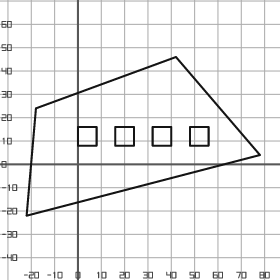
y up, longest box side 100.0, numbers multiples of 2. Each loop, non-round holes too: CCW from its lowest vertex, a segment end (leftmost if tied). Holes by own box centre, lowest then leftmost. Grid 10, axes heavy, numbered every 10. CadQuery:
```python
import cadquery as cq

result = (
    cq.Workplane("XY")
    .moveTo(-22.0, -22.0)
    .lineTo(78.0, 4.0)
    .lineTo(42.0, 46.0)
    .lineTo(-18.0, 24.0)
    .close()
    .moveTo(0.0, 8.0)
    .lineTo(8.0, 8.0)
    .lineTo(8.0, 16.0)
    .lineTo(0.0, 16.0)
    .close()
    .moveTo(16.0, 8.0)
    .lineTo(24.0, 8.0)
    .lineTo(24.0, 16.0)
    .lineTo(16.0, 16.0)
    .close()
    .moveTo(32.0, 8.0)
    .lineTo(40.0, 8.0)
    .lineTo(40.0, 16.0)
    .lineTo(32.0, 16.0)
    .close()
    .moveTo(48.0, 8.0)
    .lineTo(56.0, 8.0)
    .lineTo(56.0, 16.0)
    .lineTo(48.0, 16.0)
    .close()
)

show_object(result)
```